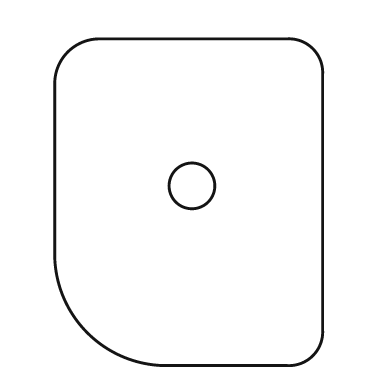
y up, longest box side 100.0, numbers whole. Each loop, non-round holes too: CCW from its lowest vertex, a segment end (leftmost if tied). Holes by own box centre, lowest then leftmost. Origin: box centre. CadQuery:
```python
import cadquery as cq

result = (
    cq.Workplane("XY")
    .moveTo(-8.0, -50.0)
    .lineTo(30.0, -50.0)
    .threePointArc((38.0, -47.0), (41.0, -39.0))
    .lineTo(41.0, 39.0)
    .threePointArc((38.0, 47.0), (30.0, 50.0))
    .lineTo(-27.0, 50.0)
    .threePointArc((-37.0, 46.0), (-41.0, 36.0))
    .lineTo(-41.0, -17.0)
    .threePointArc((-31.0, -40.0), (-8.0, -50.0))
    .close()
    .moveTo(1.0, 5.0)
    .circle(7.0)
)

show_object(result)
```